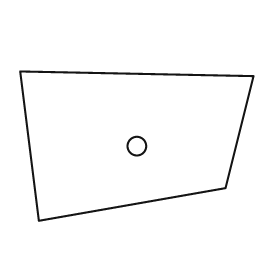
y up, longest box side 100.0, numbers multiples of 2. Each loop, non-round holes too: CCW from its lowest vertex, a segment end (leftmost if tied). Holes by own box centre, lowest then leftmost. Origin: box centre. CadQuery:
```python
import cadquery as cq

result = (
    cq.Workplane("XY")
    .moveTo(-42.0, -32.0)
    .lineTo(38.0, -18.0)
    .lineTo(50.0, 30.0)
    .lineTo(-50.0, 32.0)
    .close()
    .moveTo(0.0, 0.0)
    .circle(4.0)
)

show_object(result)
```